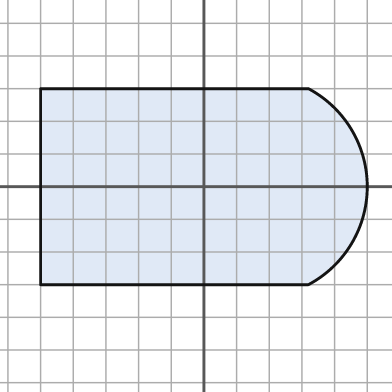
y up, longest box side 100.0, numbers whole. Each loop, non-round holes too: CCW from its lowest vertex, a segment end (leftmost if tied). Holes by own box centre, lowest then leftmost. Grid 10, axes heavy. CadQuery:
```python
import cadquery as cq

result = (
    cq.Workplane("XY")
    .moveTo(-50.0, -30.0)
    .lineTo(32.0, -30.0)
    .threePointArc((50.0, 0.0), (32.0, 30.0))
    .lineTo(-50.0, 30.0)
    .close()
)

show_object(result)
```